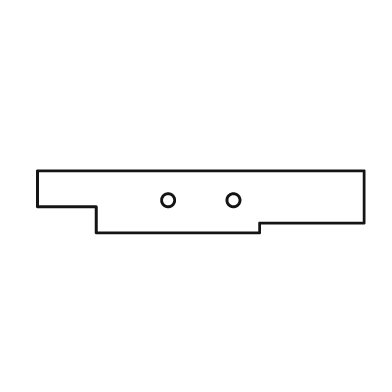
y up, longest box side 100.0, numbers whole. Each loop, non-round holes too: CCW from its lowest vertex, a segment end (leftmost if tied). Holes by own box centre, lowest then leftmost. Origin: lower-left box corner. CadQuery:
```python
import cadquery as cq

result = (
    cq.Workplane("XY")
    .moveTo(18.0, 0.0)
    .lineTo(68.0, 0.0)
    .lineTo(68.0, 3.0)
    .lineTo(100.0, 3.0)
    .lineTo(100.0, 19.0)
    .lineTo(0.0, 19.0)
    .lineTo(0.0, 8.0)
    .lineTo(18.0, 8.0)
    .close()
    .moveTo(40.0, 10.0)
    .circle(2.0)
    .moveTo(60.0, 10.0)
    .circle(2.0)
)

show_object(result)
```